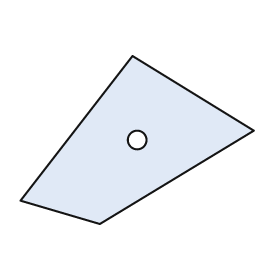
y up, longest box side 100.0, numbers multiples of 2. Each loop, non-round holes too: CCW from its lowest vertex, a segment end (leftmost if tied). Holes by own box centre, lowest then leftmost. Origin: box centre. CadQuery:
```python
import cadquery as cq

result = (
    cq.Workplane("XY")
    .moveTo(-16.0, -36.0)
    .lineTo(50.0, 4.0)
    .lineTo(-2.0, 36.0)
    .lineTo(-50.0, -26.0)
    .close()
    .moveTo(0.0, 0.0)
    .circle(4.0)
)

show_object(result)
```